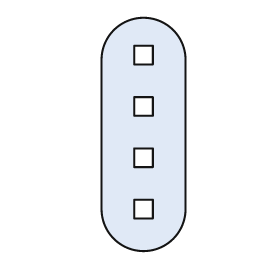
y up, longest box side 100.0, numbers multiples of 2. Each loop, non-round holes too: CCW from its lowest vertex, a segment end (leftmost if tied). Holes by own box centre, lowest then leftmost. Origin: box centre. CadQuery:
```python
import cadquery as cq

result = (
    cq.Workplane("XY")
    .moveTo(-18.0, -32.0)
    .threePointArc((0.0, -50.0), (18.0, -32.0))
    .lineTo(18.0, 32.0)
    .threePointArc((0.0, 50.0), (-18.0, 32.0))
    .close()
    .moveTo(-4.0, -36.0)
    .lineTo(4.0, -36.0)
    .lineTo(4.0, -28.0)
    .lineTo(-4.0, -28.0)
    .close()
    .moveTo(-4.0, -14.0)
    .lineTo(4.0, -14.0)
    .lineTo(4.0, -6.0)
    .lineTo(-4.0, -6.0)
    .close()
    .moveTo(-4.0, 8.0)
    .lineTo(4.0, 8.0)
    .lineTo(4.0, 16.0)
    .lineTo(-4.0, 16.0)
    .close()
    .moveTo(-4.0, 30.0)
    .lineTo(4.0, 30.0)
    .lineTo(4.0, 38.0)
    .lineTo(-4.0, 38.0)
    .close()
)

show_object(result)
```